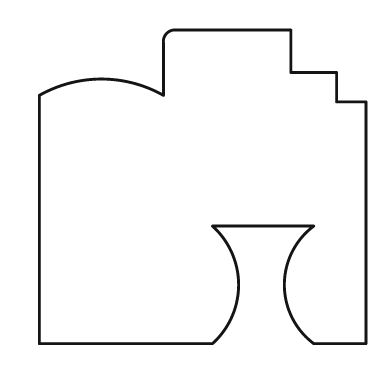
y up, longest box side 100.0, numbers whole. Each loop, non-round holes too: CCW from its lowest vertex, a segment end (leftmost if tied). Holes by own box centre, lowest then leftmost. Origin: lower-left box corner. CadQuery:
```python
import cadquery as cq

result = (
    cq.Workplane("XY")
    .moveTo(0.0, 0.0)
    .lineTo(53.0, 0.0)
    .threePointArc((61.0, 18.0), (53.0, 36.0))
    .lineTo(84.0, 36.0)
    .threePointArc((75.0, 18.0), (84.0, 0.0))
    .lineTo(100.0, 0.0)
    .lineTo(100.0, 74.0)
    .lineTo(91.0, 74.0)
    .lineTo(91.0, 83.0)
    .lineTo(77.0, 83.0)
    .lineTo(77.0, 96.0)
    .lineTo(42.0, 96.0)
    .threePointArc((39.0, 95.0), (38.0, 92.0))
    .lineTo(38.0, 76.0)
    .threePointArc((19.0, 81.0), (0.0, 76.0))
    .close()
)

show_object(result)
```